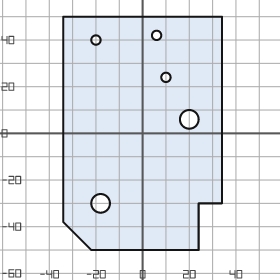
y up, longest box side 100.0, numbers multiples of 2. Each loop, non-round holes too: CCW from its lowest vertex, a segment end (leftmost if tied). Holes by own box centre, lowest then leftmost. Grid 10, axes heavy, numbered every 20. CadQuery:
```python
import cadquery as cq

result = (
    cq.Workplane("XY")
    .moveTo(-22.0, -50.0)
    .lineTo(24.0, -50.0)
    .lineTo(24.0, -30.0)
    .lineTo(34.0, -30.0)
    .lineTo(34.0, 50.0)
    .lineTo(-34.0, 50.0)
    .lineTo(-34.0, -38.0)
    .close()
    .moveTo(-18.0, -30.0)
    .circle(4.0)
    .moveTo(20.0, 6.0)
    .circle(4.0)
    .moveTo(10.0, 24.0)
    .circle(2.0)
    .moveTo(-20.0, 40.0)
    .circle(2.0)
    .moveTo(6.0, 42.0)
    .circle(2.0)
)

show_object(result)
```